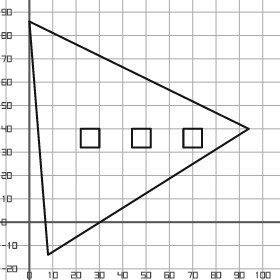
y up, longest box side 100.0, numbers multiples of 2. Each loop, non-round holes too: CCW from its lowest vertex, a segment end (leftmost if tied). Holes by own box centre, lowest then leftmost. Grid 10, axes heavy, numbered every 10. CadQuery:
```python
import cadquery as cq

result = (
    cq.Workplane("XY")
    .moveTo(8.0, -14.0)
    .lineTo(94.0, 40.0)
    .lineTo(0.0, 86.0)
    .close()
    .moveTo(22.0, 32.0)
    .lineTo(30.0, 32.0)
    .lineTo(30.0, 40.0)
    .lineTo(22.0, 40.0)
    .close()
    .moveTo(44.0, 32.0)
    .lineTo(52.0, 32.0)
    .lineTo(52.0, 40.0)
    .lineTo(44.0, 40.0)
    .close()
    .moveTo(66.0, 32.0)
    .lineTo(74.0, 32.0)
    .lineTo(74.0, 40.0)
    .lineTo(66.0, 40.0)
    .close()
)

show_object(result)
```